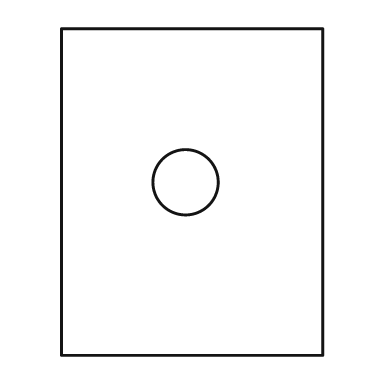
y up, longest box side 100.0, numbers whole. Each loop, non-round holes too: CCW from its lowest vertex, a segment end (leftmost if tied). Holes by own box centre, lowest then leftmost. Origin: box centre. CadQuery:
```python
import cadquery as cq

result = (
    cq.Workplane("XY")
    .moveTo(-40.0, -50.0)
    .lineTo(40.0, -50.0)
    .lineTo(40.0, 50.0)
    .lineTo(-40.0, 50.0)
    .close()
    .moveTo(-2.0, 3.0)
    .circle(10.0)
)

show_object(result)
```